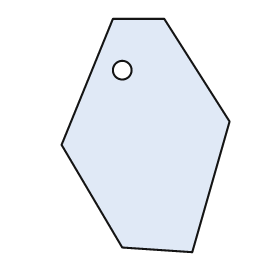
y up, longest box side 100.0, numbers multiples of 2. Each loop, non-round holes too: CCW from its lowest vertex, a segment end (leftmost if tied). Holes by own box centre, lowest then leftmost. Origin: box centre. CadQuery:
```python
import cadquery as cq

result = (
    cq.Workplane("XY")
    .moveTo(20.0, -50.0)
    .lineTo(36.0, 6.0)
    .lineTo(8.0, 50.0)
    .lineTo(-14.0, 50.0)
    .lineTo(-36.0, -4.0)
    .lineTo(-10.0, -48.0)
    .close()
    .moveTo(-10.0, 28.0)
    .circle(4.0)
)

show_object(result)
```